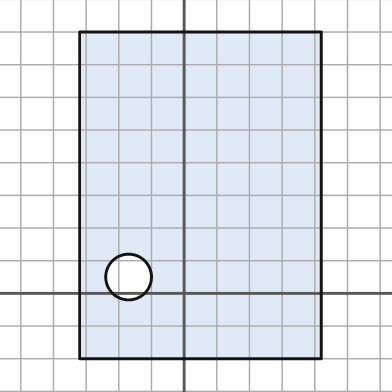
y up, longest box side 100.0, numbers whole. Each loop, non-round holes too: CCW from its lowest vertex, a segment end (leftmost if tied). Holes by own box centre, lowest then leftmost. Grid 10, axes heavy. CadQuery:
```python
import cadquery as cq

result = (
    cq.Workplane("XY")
    .moveTo(-32.0, -20.0)
    .lineTo(42.0, -20.0)
    .lineTo(42.0, 80.0)
    .lineTo(-32.0, 80.0)
    .close()
    .moveTo(-17.0, 5.0)
    .circle(7.0)
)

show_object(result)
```